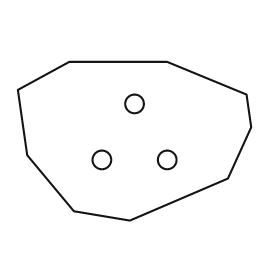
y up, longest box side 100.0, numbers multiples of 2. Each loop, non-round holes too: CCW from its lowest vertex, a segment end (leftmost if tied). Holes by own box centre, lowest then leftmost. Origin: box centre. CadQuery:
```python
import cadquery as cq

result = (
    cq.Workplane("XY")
    .moveTo(-2.0, -34.0)
    .lineTo(40.0, -16.0)
    .lineTo(50.0, 6.0)
    .lineTo(48.0, 20.0)
    .lineTo(14.0, 34.0)
    .lineTo(-28.0, 34.0)
    .lineTo(-50.0, 22.0)
    .lineTo(-46.0, -6.0)
    .lineTo(-26.0, -30.0)
    .close()
    .moveTo(-14.0, -8.0)
    .circle(4.0)
    .moveTo(14.0, -8.0)
    .circle(4.0)
    .moveTo(0.0, 16.0)
    .circle(4.0)
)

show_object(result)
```